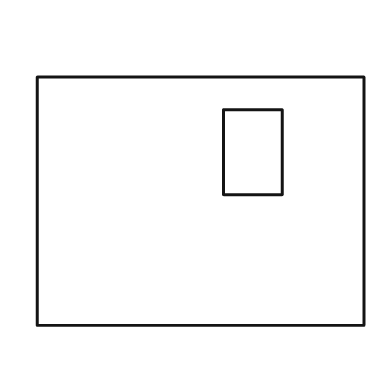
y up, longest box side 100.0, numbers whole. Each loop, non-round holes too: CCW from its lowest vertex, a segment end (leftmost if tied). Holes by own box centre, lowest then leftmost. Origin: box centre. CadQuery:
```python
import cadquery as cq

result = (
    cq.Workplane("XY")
    .moveTo(-50.0, -38.0)
    .lineTo(50.0, -38.0)
    .lineTo(50.0, 38.0)
    .lineTo(-50.0, 38.0)
    .close()
    .moveTo(7.0, 2.0)
    .lineTo(25.0, 2.0)
    .lineTo(25.0, 28.0)
    .lineTo(7.0, 28.0)
    .close()
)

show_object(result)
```